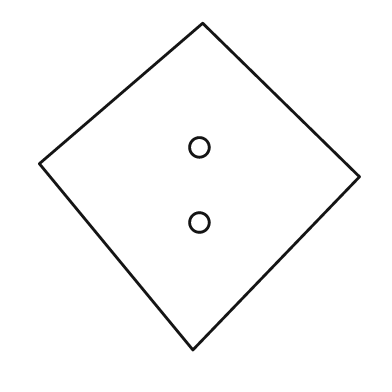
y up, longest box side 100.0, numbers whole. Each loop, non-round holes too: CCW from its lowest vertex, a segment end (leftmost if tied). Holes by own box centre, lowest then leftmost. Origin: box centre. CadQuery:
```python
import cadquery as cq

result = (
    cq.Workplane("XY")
    .moveTo(-2.0, -50.0)
    .lineTo(49.0, 3.0)
    .lineTo(1.0, 50.0)
    .lineTo(-49.0, 7.0)
    .close()
    .moveTo(0.0, -11.0)
    .circle(3.0)
    .moveTo(0.0, 12.0)
    .circle(3.0)
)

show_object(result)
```